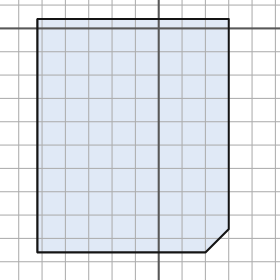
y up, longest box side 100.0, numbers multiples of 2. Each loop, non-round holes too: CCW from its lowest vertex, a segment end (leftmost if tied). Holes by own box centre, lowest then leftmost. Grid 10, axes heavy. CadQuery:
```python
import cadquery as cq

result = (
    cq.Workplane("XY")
    .moveTo(-52.0, -96.0)
    .lineTo(20.0, -96.0)
    .lineTo(30.0, -86.0)
    .lineTo(30.0, 4.0)
    .lineTo(-52.0, 4.0)
    .close()
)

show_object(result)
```